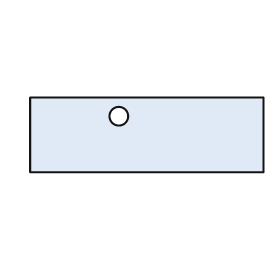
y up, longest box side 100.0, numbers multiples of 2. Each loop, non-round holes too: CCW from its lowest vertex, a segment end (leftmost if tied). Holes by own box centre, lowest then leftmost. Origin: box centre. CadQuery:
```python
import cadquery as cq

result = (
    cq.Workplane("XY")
    .moveTo(-50.0, -16.0)
    .lineTo(50.0, -16.0)
    .lineTo(50.0, 16.0)
    .lineTo(-50.0, 16.0)
    .close()
    .moveTo(-12.0, 8.0)
    .circle(4.0)
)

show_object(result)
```